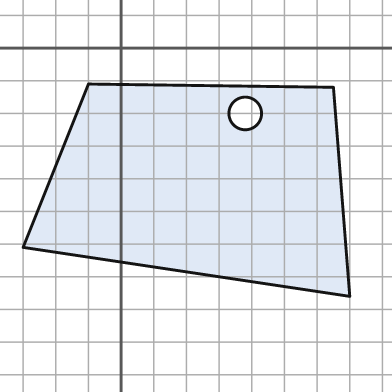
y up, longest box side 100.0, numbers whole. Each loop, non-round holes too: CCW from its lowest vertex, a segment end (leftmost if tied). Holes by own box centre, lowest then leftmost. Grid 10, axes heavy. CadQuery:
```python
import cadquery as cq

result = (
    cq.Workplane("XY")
    .moveTo(70.0, -76.0)
    .lineTo(65.0, -12.0)
    .lineTo(-10.0, -11.0)
    .lineTo(-30.0, -61.0)
    .close()
    .moveTo(38.0, -20.0)
    .circle(5.0)
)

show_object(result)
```